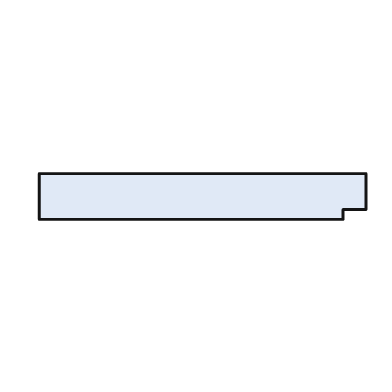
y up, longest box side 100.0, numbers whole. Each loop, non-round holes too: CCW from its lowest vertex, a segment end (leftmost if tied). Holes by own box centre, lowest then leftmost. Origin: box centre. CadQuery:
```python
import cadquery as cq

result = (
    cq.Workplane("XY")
    .moveTo(-50.0, -7.0)
    .lineTo(43.0, -7.0)
    .lineTo(43.0, -4.0)
    .lineTo(50.0, -4.0)
    .lineTo(50.0, 7.0)
    .lineTo(-50.0, 7.0)
    .close()
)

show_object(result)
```